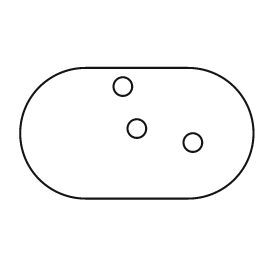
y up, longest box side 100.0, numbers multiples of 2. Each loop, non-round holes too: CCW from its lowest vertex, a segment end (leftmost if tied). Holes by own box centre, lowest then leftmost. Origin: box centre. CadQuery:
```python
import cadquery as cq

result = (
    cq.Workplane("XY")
    .moveTo(-22.0, -28.0)
    .lineTo(22.0, -28.0)
    .threePointArc((50.0, 0.0), (22.0, 28.0))
    .lineTo(-22.0, 28.0)
    .threePointArc((-50.0, 0.0), (-22.0, -28.0))
    .close()
    .moveTo(24.0, -4.0)
    .circle(4.0)
    .moveTo(0.0, 2.0)
    .circle(4.0)
    .moveTo(-6.0, 20.0)
    .circle(4.0)
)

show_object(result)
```